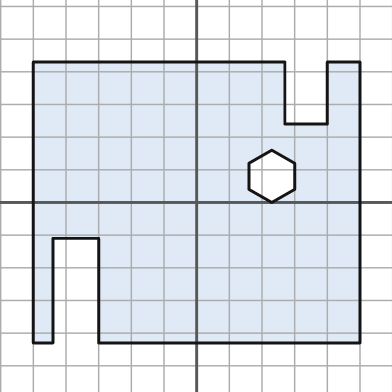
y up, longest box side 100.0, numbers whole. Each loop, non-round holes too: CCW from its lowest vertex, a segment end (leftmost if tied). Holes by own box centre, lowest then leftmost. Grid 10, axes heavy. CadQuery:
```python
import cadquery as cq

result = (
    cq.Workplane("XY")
    .moveTo(-50.0, -43.0)
    .lineTo(-44.0, -43.0)
    .lineTo(-44.0, -11.0)
    .lineTo(-30.0, -11.0)
    .lineTo(-30.0, -43.0)
    .lineTo(50.0, -43.0)
    .lineTo(50.0, 43.0)
    .lineTo(40.0, 43.0)
    .lineTo(40.0, 24.0)
    .lineTo(27.0, 24.0)
    .lineTo(27.0, 43.0)
    .lineTo(-50.0, 43.0)
    .close()
    .moveTo(23.0, 0.0)
    .lineTo(30.0, 4.0)
    .lineTo(30.0, 12.0)
    .lineTo(23.0, 16.0)
    .lineTo(16.0, 12.0)
    .lineTo(16.0, 4.0)
    .close()
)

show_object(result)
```